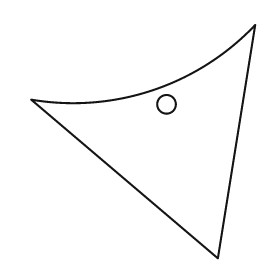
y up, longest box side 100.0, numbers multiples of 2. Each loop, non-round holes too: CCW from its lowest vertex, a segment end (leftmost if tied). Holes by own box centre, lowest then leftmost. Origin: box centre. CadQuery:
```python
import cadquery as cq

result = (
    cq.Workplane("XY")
    .moveTo(32.0, -50.0)
    .lineTo(48.0, 50.0)
    .threePointArc((4.0, 22.0), (-48.0, 18.0))
    .close()
    .moveTo(10.0, 16.0)
    .circle(4.0)
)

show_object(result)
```